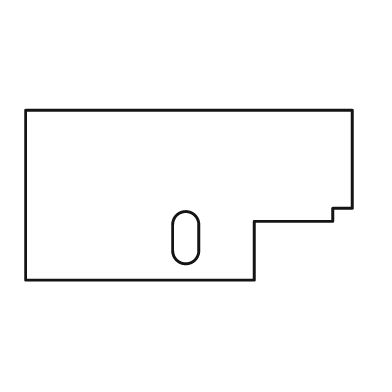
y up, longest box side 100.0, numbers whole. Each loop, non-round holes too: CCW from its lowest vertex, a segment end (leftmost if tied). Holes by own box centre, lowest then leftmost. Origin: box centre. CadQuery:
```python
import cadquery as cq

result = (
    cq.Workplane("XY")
    .moveTo(-50.0, -26.0)
    .lineTo(20.0, -26.0)
    .lineTo(20.0, -8.0)
    .lineTo(44.0, -8.0)
    .lineTo(44.0, -4.0)
    .lineTo(50.0, -4.0)
    .lineTo(50.0, 26.0)
    .lineTo(-50.0, 26.0)
    .close()
    .moveTo(-5.0, -17.0)
    .threePointArc((-1.0, -21.0), (3.0, -17.0))
    .lineTo(3.0, -9.0)
    .threePointArc((-1.0, -5.0), (-5.0, -9.0))
    .close()
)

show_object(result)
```